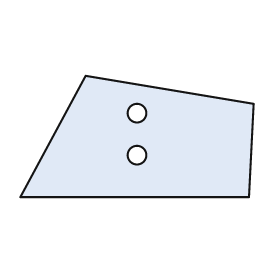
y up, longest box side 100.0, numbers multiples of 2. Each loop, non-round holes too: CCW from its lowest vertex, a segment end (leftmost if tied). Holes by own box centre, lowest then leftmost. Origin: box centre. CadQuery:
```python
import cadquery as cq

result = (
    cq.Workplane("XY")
    .moveTo(-50.0, -26.0)
    .lineTo(48.0, -26.0)
    .lineTo(50.0, 14.0)
    .lineTo(-22.0, 26.0)
    .close()
    .moveTo(0.0, -8.0)
    .circle(4.0)
    .moveTo(0.0, 10.0)
    .circle(4.0)
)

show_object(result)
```